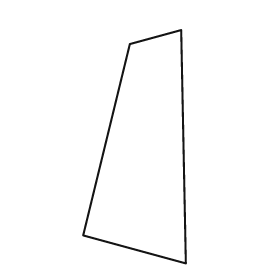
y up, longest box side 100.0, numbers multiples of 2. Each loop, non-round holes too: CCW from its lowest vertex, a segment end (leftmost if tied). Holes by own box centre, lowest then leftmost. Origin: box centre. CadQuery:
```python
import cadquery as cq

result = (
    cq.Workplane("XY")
    .moveTo(22.0, -50.0)
    .lineTo(20.0, 50.0)
    .lineTo(-2.0, 44.0)
    .lineTo(-22.0, -38.0)
    .close()
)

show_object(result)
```